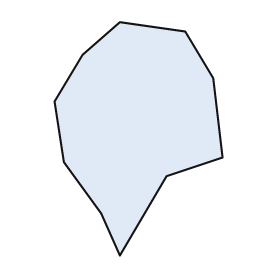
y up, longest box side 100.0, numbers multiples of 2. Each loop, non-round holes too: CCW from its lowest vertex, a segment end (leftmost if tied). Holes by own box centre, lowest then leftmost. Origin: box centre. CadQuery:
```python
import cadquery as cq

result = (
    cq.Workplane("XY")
    .moveTo(-8.0, -50.0)
    .lineTo(12.0, -16.0)
    .lineTo(36.0, -8.0)
    .lineTo(32.0, 26.0)
    .lineTo(20.0, 46.0)
    .lineTo(-8.0, 50.0)
    .lineTo(-24.0, 36.0)
    .lineTo(-36.0, 16.0)
    .lineTo(-32.0, -10.0)
    .lineTo(-16.0, -32.0)
    .close()
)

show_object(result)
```